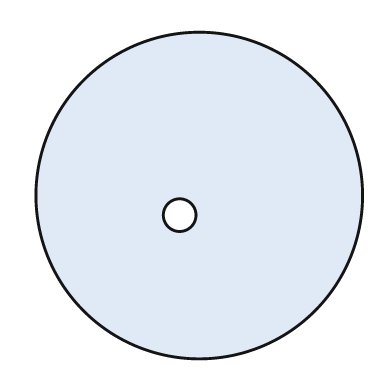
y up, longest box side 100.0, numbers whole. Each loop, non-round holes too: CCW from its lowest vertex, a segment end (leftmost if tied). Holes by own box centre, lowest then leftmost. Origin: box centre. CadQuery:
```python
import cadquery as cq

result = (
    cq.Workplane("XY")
    .moveTo(0.0, 0.0)
    .circle(50.0)
    .moveTo(-6.0, -6.0)
    .circle(5.0)
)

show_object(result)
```